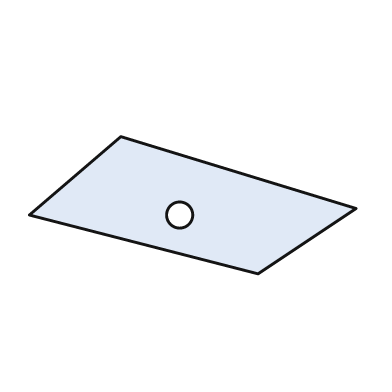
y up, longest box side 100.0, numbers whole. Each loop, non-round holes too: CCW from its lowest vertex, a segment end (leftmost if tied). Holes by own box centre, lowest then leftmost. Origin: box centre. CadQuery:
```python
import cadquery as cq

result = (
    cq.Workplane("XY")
    .moveTo(20.0, -21.0)
    .lineTo(50.0, -1.0)
    .lineTo(-22.0, 21.0)
    .lineTo(-50.0, -3.0)
    .close()
    .moveTo(-4.0, -3.0)
    .circle(4.0)
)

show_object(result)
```